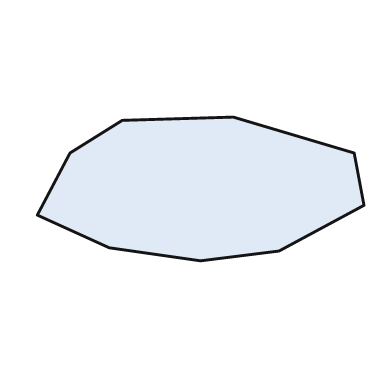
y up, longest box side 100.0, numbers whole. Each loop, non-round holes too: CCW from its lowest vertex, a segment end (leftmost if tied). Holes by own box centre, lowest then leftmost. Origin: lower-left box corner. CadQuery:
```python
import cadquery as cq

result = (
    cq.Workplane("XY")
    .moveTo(50.0, 0.0)
    .lineTo(74.0, 3.0)
    .lineTo(100.0, 17.0)
    .lineTo(97.0, 33.0)
    .lineTo(60.0, 44.0)
    .lineTo(26.0, 43.0)
    .lineTo(10.0, 33.0)
    .lineTo(0.0, 14.0)
    .lineTo(22.0, 4.0)
    .close()
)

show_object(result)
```